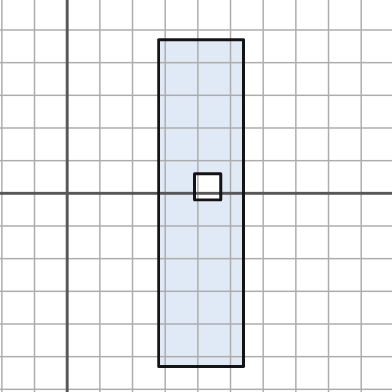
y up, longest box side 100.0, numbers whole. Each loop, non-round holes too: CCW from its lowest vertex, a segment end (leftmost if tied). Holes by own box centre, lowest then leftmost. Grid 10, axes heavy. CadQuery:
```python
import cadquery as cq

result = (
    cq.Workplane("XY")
    .moveTo(28.0, -53.0)
    .lineTo(54.0, -53.0)
    .lineTo(54.0, 47.0)
    .lineTo(28.0, 47.0)
    .close()
    .moveTo(39.0, -2.0)
    .lineTo(47.0, -2.0)
    .lineTo(47.0, 6.0)
    .lineTo(39.0, 6.0)
    .close()
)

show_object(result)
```